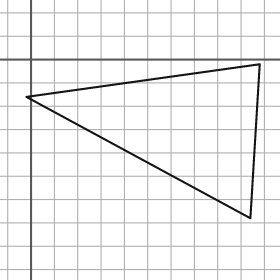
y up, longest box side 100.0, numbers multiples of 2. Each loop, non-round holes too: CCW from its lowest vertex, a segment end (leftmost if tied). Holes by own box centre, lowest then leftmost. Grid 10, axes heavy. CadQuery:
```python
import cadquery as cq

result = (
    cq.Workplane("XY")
    .moveTo(94.0, -68.0)
    .lineTo(98.0, -2.0)
    .lineTo(-2.0, -16.0)
    .close()
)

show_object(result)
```